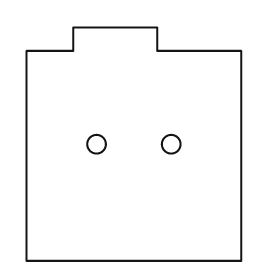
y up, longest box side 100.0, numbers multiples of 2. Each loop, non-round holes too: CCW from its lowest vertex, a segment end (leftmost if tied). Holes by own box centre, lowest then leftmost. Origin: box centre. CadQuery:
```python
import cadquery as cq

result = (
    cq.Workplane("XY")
    .moveTo(-46.0, -50.0)
    .lineTo(46.0, -50.0)
    .lineTo(46.0, 40.0)
    .lineTo(10.0, 40.0)
    .lineTo(10.0, 50.0)
    .lineTo(-26.0, 50.0)
    .lineTo(-26.0, 40.0)
    .lineTo(-46.0, 40.0)
    .close()
    .moveTo(-16.0, 0.0)
    .circle(4.0)
    .moveTo(16.0, 0.0)
    .circle(4.0)
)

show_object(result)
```